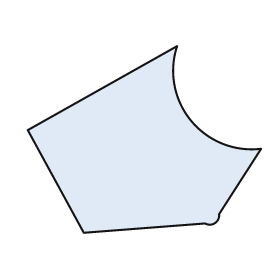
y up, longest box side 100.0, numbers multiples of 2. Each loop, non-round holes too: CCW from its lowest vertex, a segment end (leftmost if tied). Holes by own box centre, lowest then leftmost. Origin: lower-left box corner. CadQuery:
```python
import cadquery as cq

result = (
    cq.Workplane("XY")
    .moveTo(24.0, 0.0)
    .lineTo(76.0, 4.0)
    .threePointArc((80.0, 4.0), (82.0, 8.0))
    .lineTo(100.0, 36.0)
    .threePointArc((70.0, 48.0), (64.0, 80.0))
    .lineTo(0.0, 44.0)
    .close()
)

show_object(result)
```